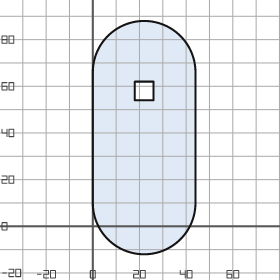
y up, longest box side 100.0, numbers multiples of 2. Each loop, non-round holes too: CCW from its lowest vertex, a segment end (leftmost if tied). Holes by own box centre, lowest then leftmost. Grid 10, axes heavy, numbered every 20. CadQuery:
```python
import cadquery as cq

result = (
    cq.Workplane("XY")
    .moveTo(0.0, 10.0)
    .threePointArc((22.0, -12.0), (44.0, 10.0))
    .lineTo(44.0, 66.0)
    .threePointArc((22.0, 88.0), (0.0, 66.0))
    .close()
    .moveTo(18.0, 54.0)
    .lineTo(26.0, 54.0)
    .lineTo(26.0, 62.0)
    .lineTo(18.0, 62.0)
    .close()
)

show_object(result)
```